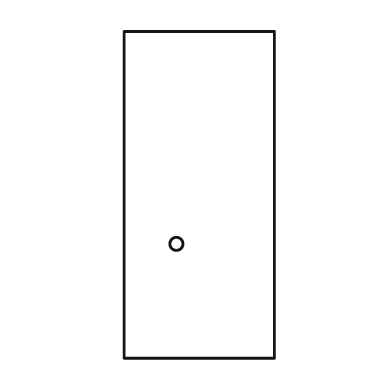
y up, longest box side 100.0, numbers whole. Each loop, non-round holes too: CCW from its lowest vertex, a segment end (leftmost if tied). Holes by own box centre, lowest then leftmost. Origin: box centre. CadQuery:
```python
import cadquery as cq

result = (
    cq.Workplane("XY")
    .moveTo(-23.0, -50.0)
    .lineTo(23.0, -50.0)
    .lineTo(23.0, 50.0)
    .lineTo(-23.0, 50.0)
    .close()
    .moveTo(-7.0, -15.0)
    .circle(2.0)
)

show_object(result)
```